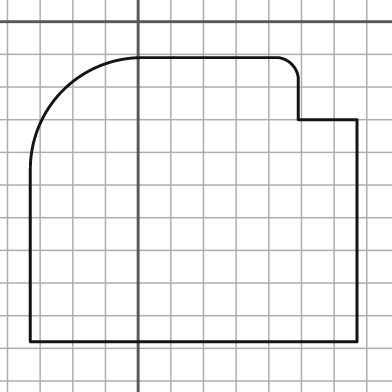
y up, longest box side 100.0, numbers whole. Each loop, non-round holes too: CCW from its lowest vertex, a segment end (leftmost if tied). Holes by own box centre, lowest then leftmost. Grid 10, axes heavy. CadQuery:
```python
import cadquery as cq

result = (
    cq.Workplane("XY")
    .moveTo(-33.0, -98.0)
    .lineTo(67.0, -98.0)
    .lineTo(67.0, -30.0)
    .lineTo(49.0, -30.0)
    .lineTo(49.0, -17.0)
    .threePointArc((47.0, -13.0), (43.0, -11.0))
    .lineTo(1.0, -11.0)
    .threePointArc((-23.0, -21.0), (-33.0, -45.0))
    .close()
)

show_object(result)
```